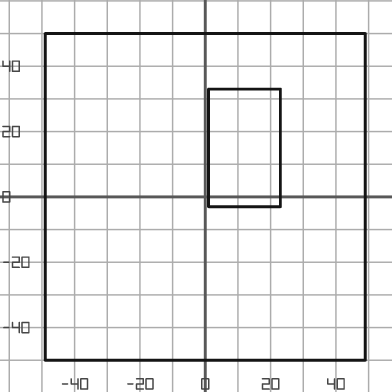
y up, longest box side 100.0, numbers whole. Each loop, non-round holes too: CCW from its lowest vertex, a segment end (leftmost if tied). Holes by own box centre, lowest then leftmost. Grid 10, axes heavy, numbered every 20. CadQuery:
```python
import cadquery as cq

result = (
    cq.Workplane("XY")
    .moveTo(-49.0, -50.0)
    .lineTo(49.0, -50.0)
    .lineTo(49.0, 50.0)
    .lineTo(-49.0, 50.0)
    .close()
    .moveTo(1.0, -3.0)
    .lineTo(23.0, -3.0)
    .lineTo(23.0, 33.0)
    .lineTo(1.0, 33.0)
    .close()
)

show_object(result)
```